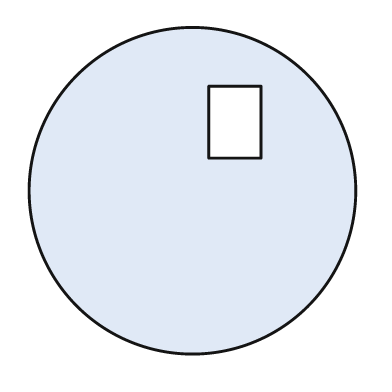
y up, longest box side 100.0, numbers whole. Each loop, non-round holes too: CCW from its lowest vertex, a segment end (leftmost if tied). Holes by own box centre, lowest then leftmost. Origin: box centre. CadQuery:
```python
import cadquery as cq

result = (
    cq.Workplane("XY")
    .moveTo(0.0, 0.0)
    .circle(50.0)
    .moveTo(5.0, 10.0)
    .lineTo(21.0, 10.0)
    .lineTo(21.0, 32.0)
    .lineTo(5.0, 32.0)
    .close()
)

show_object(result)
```